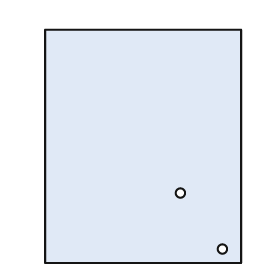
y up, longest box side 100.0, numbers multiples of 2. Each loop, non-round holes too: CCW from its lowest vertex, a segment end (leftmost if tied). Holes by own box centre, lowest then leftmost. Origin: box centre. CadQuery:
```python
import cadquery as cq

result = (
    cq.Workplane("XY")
    .moveTo(-42.0, -50.0)
    .lineTo(42.0, -50.0)
    .lineTo(42.0, 50.0)
    .lineTo(-42.0, 50.0)
    .close()
    .moveTo(34.0, -44.0)
    .circle(2.0)
    .moveTo(16.0, -20.0)
    .circle(2.0)
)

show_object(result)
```